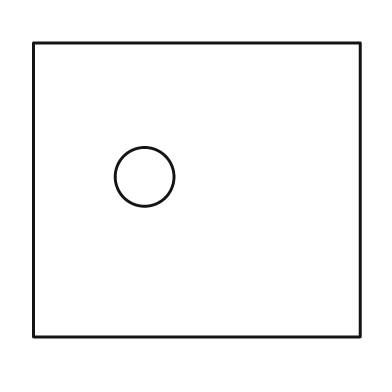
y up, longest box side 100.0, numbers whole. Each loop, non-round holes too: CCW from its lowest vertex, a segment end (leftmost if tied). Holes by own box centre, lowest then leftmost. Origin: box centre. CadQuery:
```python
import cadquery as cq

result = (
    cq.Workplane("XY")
    .moveTo(-50.0, -45.0)
    .lineTo(50.0, -45.0)
    .lineTo(50.0, 45.0)
    .lineTo(-50.0, 45.0)
    .close()
    .moveTo(-16.0, 4.0)
    .circle(9.0)
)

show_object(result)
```